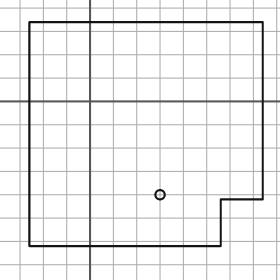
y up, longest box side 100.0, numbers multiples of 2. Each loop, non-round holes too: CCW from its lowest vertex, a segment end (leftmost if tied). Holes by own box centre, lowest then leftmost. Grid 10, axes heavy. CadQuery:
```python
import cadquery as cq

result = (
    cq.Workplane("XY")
    .moveTo(-26.0, -62.0)
    .lineTo(56.0, -62.0)
    .lineTo(56.0, -42.0)
    .lineTo(74.0, -42.0)
    .lineTo(74.0, 34.0)
    .lineTo(-26.0, 34.0)
    .close()
    .moveTo(30.0, -40.0)
    .circle(2.0)
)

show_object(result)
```